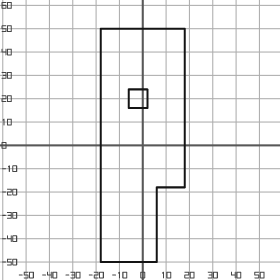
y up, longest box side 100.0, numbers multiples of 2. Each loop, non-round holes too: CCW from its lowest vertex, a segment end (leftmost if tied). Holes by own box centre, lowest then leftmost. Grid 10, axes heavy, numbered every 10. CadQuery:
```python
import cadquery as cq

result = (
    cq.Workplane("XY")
    .moveTo(-18.0, -50.0)
    .lineTo(6.0, -50.0)
    .lineTo(6.0, -18.0)
    .lineTo(18.0, -18.0)
    .lineTo(18.0, 50.0)
    .lineTo(-18.0, 50.0)
    .close()
    .moveTo(-6.0, 16.0)
    .lineTo(2.0, 16.0)
    .lineTo(2.0, 24.0)
    .lineTo(-6.0, 24.0)
    .close()
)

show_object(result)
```